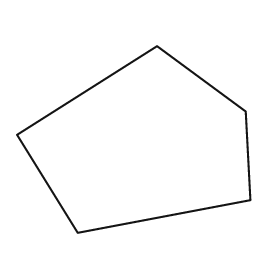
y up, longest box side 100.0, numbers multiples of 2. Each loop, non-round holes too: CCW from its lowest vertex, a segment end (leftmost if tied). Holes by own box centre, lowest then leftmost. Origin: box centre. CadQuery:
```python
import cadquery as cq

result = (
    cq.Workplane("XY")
    .moveTo(-24.0, -40.0)
    .lineTo(50.0, -26.0)
    .lineTo(48.0, 12.0)
    .lineTo(10.0, 40.0)
    .lineTo(-50.0, 2.0)
    .close()
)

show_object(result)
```